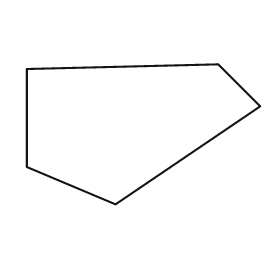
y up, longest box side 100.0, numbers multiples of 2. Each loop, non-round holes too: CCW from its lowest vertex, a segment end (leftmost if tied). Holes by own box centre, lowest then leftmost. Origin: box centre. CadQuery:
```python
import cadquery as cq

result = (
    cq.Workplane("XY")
    .moveTo(-12.0, -30.0)
    .lineTo(50.0, 12.0)
    .lineTo(32.0, 30.0)
    .lineTo(-50.0, 28.0)
    .lineTo(-50.0, -14.0)
    .close()
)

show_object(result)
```